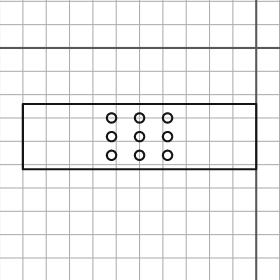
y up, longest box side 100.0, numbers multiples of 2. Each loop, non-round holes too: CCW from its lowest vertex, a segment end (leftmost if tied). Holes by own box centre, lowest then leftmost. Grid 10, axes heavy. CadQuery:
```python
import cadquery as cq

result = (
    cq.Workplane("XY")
    .moveTo(-100.0, -52.0)
    .lineTo(0.0, -52.0)
    .lineTo(0.0, -24.0)
    .lineTo(-100.0, -24.0)
    .close()
    .moveTo(-62.0, -46.0)
    .circle(2.0)
    .moveTo(-50.0, -46.0)
    .circle(2.0)
    .moveTo(-38.0, -46.0)
    .circle(2.0)
    .moveTo(-62.0, -38.0)
    .circle(2.0)
    .moveTo(-50.0, -38.0)
    .circle(2.0)
    .moveTo(-38.0, -38.0)
    .circle(2.0)
    .moveTo(-62.0, -30.0)
    .circle(2.0)
    .moveTo(-50.0, -30.0)
    .circle(2.0)
    .moveTo(-38.0, -30.0)
    .circle(2.0)
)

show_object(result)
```